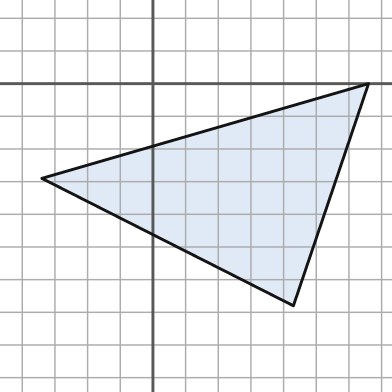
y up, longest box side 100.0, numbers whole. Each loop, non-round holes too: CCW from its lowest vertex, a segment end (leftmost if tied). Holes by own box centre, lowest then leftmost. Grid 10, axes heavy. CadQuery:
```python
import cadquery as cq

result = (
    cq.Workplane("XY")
    .moveTo(43.0, -68.0)
    .lineTo(66.0, 0.0)
    .lineTo(-34.0, -29.0)
    .close()
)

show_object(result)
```